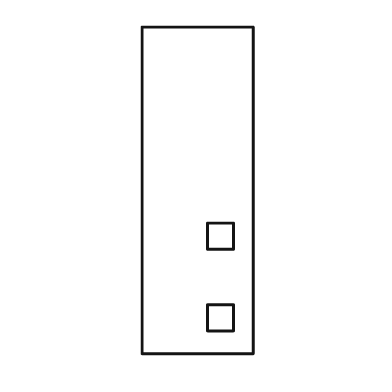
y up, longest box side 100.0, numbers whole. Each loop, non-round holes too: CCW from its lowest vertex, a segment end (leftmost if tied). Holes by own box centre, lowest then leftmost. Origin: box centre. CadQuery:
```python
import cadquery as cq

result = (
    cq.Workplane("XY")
    .moveTo(-17.0, -50.0)
    .lineTo(17.0, -50.0)
    .lineTo(17.0, 50.0)
    .lineTo(-17.0, 50.0)
    .close()
    .moveTo(3.0, -43.0)
    .lineTo(11.0, -43.0)
    .lineTo(11.0, -35.0)
    .lineTo(3.0, -35.0)
    .close()
    .moveTo(3.0, -18.0)
    .lineTo(11.0, -18.0)
    .lineTo(11.0, -10.0)
    .lineTo(3.0, -10.0)
    .close()
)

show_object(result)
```